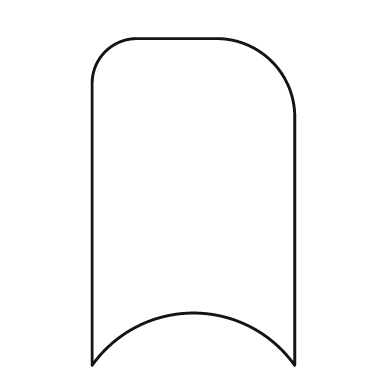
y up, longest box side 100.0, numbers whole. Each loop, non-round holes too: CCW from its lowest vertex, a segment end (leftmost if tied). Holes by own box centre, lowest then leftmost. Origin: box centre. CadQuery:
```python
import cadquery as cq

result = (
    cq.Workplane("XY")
    .moveTo(-31.0, -50.0)
    .threePointArc((0.0, -34.0), (31.0, -50.0))
    .lineTo(31.0, 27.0)
    .threePointArc((24.0, 43.0), (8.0, 50.0))
    .lineTo(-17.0, 50.0)
    .threePointArc((-27.0, 46.0), (-31.0, 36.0))
    .close()
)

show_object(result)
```